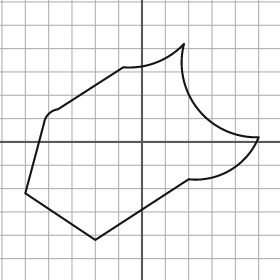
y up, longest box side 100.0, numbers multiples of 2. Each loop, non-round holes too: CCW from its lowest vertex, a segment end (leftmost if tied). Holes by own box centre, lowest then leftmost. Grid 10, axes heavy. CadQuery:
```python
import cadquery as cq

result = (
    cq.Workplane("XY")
    .moveTo(-20.0, -42.0)
    .lineTo(20.0, -16.0)
    .threePointArc((38.0, -12.0), (50.0, 2.0))
    .threePointArc((24.0, 14.0), (18.0, 42.0))
    .threePointArc((6.0, 34.0), (-8.0, 32.0))
    .lineTo(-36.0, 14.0)
    .threePointArc((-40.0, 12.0), (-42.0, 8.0))
    .lineTo(-50.0, -22.0)
    .close()
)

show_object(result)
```